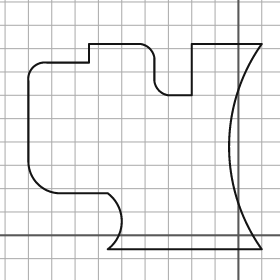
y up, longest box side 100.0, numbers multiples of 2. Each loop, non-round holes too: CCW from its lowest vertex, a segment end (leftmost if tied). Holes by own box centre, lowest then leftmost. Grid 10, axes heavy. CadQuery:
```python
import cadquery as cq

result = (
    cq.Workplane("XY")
    .moveTo(-56.0, -6.0)
    .lineTo(10.0, -6.0)
    .threePointArc((-4.0, 38.0), (10.0, 82.0))
    .lineTo(-20.0, 82.0)
    .lineTo(-20.0, 60.0)
    .lineTo(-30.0, 60.0)
    .threePointArc((-34.0, 62.0), (-36.0, 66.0))
    .lineTo(-36.0, 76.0)
    .threePointArc((-38.0, 80.0), (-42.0, 82.0))
    .lineTo(-64.0, 82.0)
    .lineTo(-64.0, 74.0)
    .lineTo(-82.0, 74.0)
    .threePointArc((-88.0, 72.0), (-90.0, 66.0))
    .lineTo(-90.0, 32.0)
    .threePointArc((-86.0, 22.0), (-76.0, 18.0))
    .lineTo(-56.0, 18.0)
    .threePointArc((-50.0, 6.0), (-56.0, -6.0))
    .close()
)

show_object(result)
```